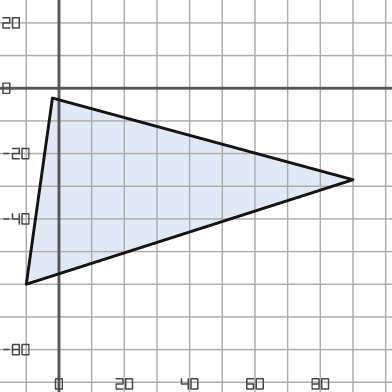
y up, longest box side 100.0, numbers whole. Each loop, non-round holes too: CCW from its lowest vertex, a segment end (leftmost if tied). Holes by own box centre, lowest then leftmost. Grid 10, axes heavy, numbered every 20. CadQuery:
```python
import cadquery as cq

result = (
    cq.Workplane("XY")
    .moveTo(-10.0, -60.0)
    .lineTo(90.0, -28.0)
    .lineTo(-2.0, -3.0)
    .close()
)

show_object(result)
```